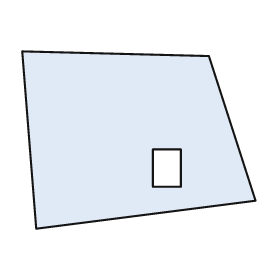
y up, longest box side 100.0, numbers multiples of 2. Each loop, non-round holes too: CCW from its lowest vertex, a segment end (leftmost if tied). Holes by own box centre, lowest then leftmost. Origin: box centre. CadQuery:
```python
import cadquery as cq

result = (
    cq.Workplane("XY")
    .moveTo(-44.0, -38.0)
    .lineTo(50.0, -26.0)
    .lineTo(30.0, 36.0)
    .lineTo(-50.0, 38.0)
    .close()
    .moveTo(6.0, -20.0)
    .lineTo(18.0, -20.0)
    .lineTo(18.0, -4.0)
    .lineTo(6.0, -4.0)
    .close()
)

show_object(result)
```